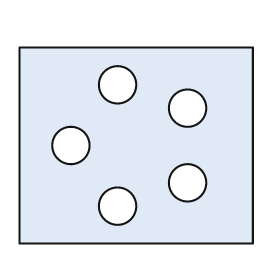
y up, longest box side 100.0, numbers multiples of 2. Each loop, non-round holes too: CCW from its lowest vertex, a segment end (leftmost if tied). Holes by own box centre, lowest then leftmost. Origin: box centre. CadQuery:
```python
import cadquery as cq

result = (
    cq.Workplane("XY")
    .moveTo(-50.0, -42.0)
    .lineTo(50.0, -42.0)
    .lineTo(50.0, 42.0)
    .lineTo(-50.0, 42.0)
    .close()
    .moveTo(-8.0, -26.0)
    .circle(8.0)
    .moveTo(22.0, -16.0)
    .circle(8.0)
    .moveTo(-28.0, 0.0)
    .circle(8.0)
    .moveTo(22.0, 16.0)
    .circle(8.0)
    .moveTo(-8.0, 26.0)
    .circle(8.0)
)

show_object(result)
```